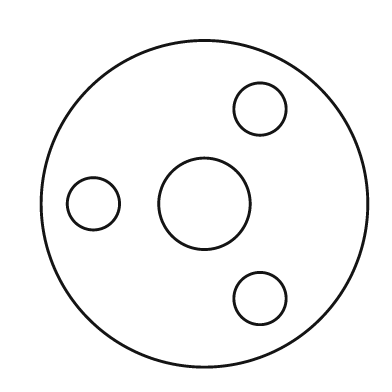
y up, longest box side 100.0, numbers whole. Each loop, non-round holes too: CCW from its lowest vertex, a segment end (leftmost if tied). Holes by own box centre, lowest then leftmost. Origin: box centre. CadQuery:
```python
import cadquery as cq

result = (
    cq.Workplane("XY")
    .moveTo(0.0, 0.0)
    .circle(50.0)
    .moveTo(17.0, -29.0)
    .circle(8.0)
    .moveTo(-34.0, 0.0)
    .circle(8.0)
    .moveTo(0.0, 0.0)
    .circle(14.0)
    .moveTo(17.0, 29.0)
    .circle(8.0)
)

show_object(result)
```